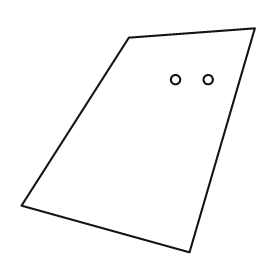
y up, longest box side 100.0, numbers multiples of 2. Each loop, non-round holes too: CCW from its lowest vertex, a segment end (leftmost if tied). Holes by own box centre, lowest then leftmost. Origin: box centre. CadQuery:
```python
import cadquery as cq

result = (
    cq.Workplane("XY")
    .moveTo(22.0, -48.0)
    .lineTo(50.0, 48.0)
    .lineTo(-4.0, 44.0)
    .lineTo(-50.0, -28.0)
    .close()
    .moveTo(16.0, 26.0)
    .circle(2.0)
    .moveTo(30.0, 26.0)
    .circle(2.0)
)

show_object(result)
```